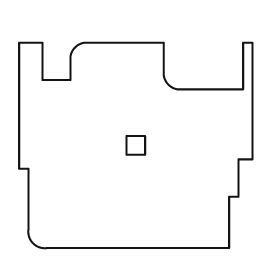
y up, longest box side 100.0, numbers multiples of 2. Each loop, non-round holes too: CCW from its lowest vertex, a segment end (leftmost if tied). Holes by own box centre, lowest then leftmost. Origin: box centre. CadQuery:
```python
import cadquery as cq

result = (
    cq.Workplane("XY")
    .moveTo(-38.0, -44.0)
    .lineTo(40.0, -44.0)
    .lineTo(40.0, -22.0)
    .lineTo(44.0, -22.0)
    .lineTo(44.0, -6.0)
    .lineTo(50.0, -6.0)
    .lineTo(50.0, 44.0)
    .lineTo(46.0, 44.0)
    .lineTo(46.0, 24.0)
    .lineTo(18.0, 24.0)
    .threePointArc((14.0, 26.0), (12.0, 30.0))
    .lineTo(12.0, 44.0)
    .lineTo(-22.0, 44.0)
    .threePointArc((-26.0, 42.0), (-28.0, 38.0))
    .lineTo(-28.0, 28.0)
    .lineTo(-40.0, 28.0)
    .lineTo(-40.0, 44.0)
    .lineTo(-50.0, 44.0)
    .lineTo(-50.0, -10.0)
    .lineTo(-46.0, -10.0)
    .lineTo(-46.0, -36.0)
    .threePointArc((-44.0, -42.0), (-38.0, -44.0))
    .close()
    .moveTo(-4.0, -4.0)
    .lineTo(4.0, -4.0)
    .lineTo(4.0, 4.0)
    .lineTo(-4.0, 4.0)
    .close()
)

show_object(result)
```